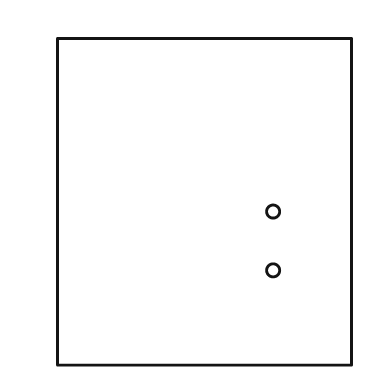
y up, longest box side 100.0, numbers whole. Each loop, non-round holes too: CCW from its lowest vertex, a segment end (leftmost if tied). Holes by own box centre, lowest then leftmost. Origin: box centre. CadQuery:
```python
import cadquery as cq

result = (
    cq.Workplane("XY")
    .moveTo(-45.0, -50.0)
    .lineTo(45.0, -50.0)
    .lineTo(45.0, 50.0)
    .lineTo(-45.0, 50.0)
    .close()
    .moveTo(21.0, -21.0)
    .circle(2.0)
    .moveTo(21.0, -3.0)
    .circle(2.0)
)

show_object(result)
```